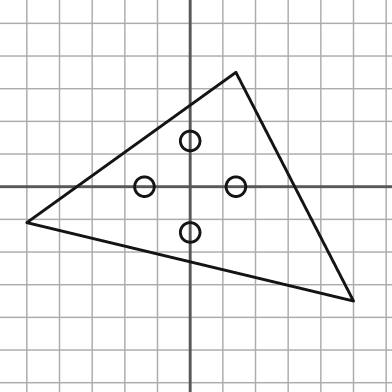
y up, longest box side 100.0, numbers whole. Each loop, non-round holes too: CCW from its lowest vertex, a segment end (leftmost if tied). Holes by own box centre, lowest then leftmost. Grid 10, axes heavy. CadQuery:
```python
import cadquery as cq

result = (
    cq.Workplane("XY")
    .moveTo(50.0, -35.0)
    .lineTo(14.0, 35.0)
    .lineTo(-50.0, -11.0)
    .close()
    .moveTo(0.0, -14.0)
    .circle(3.0)
    .moveTo(-14.0, 0.0)
    .circle(3.0)
    .moveTo(14.0, 0.0)
    .circle(3.0)
    .moveTo(0.0, 14.0)
    .circle(3.0)
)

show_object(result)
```